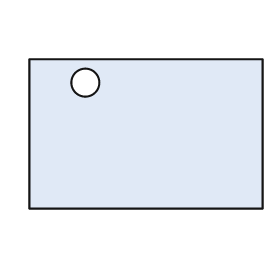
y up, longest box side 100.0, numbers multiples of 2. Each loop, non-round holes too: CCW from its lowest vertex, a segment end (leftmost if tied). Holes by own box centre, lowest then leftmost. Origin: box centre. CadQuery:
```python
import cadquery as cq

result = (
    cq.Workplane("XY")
    .moveTo(-50.0, -32.0)
    .lineTo(50.0, -32.0)
    .lineTo(50.0, 32.0)
    .lineTo(-50.0, 32.0)
    .close()
    .moveTo(-26.0, 22.0)
    .circle(6.0)
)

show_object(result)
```